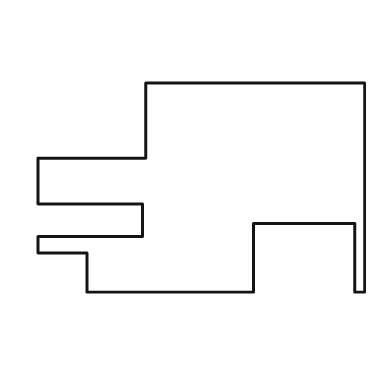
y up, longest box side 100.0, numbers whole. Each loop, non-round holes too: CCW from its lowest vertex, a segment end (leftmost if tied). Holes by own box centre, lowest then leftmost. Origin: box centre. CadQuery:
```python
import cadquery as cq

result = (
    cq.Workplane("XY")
    .moveTo(-35.0, -32.0)
    .lineTo(16.0, -32.0)
    .lineTo(16.0, -11.0)
    .lineTo(47.0, -11.0)
    .lineTo(47.0, -32.0)
    .lineTo(50.0, -32.0)
    .lineTo(50.0, 32.0)
    .lineTo(-17.0, 32.0)
    .lineTo(-17.0, 9.0)
    .lineTo(-50.0, 9.0)
    .lineTo(-50.0, -5.0)
    .lineTo(-18.0, -5.0)
    .lineTo(-18.0, -15.0)
    .lineTo(-50.0, -15.0)
    .lineTo(-50.0, -20.0)
    .lineTo(-35.0, -20.0)
    .close()
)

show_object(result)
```